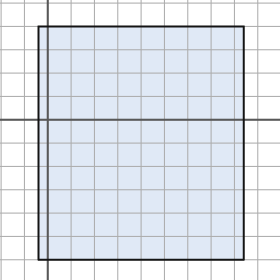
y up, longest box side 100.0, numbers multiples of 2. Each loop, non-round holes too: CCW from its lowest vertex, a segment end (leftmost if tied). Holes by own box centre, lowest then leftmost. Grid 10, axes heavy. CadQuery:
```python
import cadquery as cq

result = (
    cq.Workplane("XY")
    .moveTo(-4.0, -60.0)
    .lineTo(84.0, -60.0)
    .lineTo(84.0, 40.0)
    .lineTo(-4.0, 40.0)
    .close()
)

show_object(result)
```